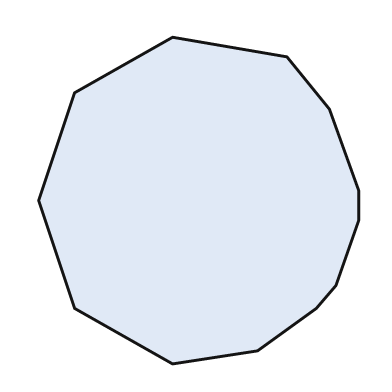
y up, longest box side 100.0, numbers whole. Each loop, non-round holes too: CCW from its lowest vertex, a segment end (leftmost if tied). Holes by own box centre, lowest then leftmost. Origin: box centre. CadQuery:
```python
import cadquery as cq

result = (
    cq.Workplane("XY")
    .moveTo(-8.0, -50.0)
    .lineTo(18.0, -46.0)
    .lineTo(36.0, -33.0)
    .lineTo(42.0, -26.0)
    .lineTo(49.0, -6.0)
    .lineTo(49.0, 3.0)
    .lineTo(40.0, 28.0)
    .lineTo(27.0, 44.0)
    .lineTo(-8.0, 50.0)
    .lineTo(-38.0, 33.0)
    .lineTo(-49.0, 0.0)
    .lineTo(-38.0, -33.0)
    .close()
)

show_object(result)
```